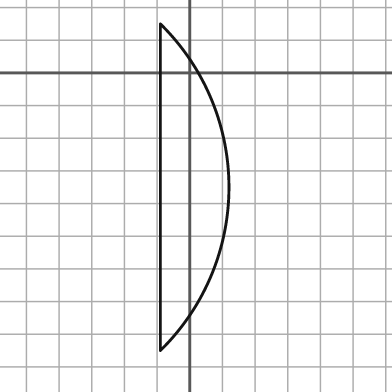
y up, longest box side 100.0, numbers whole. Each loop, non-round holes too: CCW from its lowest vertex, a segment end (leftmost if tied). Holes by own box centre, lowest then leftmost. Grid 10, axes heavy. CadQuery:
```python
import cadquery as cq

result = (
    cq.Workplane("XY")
    .moveTo(-9.0, -85.0)
    .threePointArc((12.0, -35.0), (-9.0, 15.0))
    .close()
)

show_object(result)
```